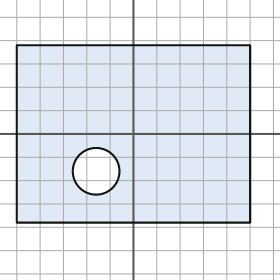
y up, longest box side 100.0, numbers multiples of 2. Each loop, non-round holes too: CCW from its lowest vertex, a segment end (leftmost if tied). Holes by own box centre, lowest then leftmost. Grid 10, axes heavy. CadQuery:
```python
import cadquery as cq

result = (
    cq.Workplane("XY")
    .moveTo(-50.0, -38.0)
    .lineTo(50.0, -38.0)
    .lineTo(50.0, 38.0)
    .lineTo(-50.0, 38.0)
    .close()
    .moveTo(-16.0, -16.0)
    .circle(10.0)
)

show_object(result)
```